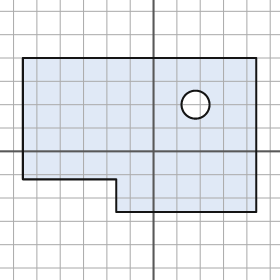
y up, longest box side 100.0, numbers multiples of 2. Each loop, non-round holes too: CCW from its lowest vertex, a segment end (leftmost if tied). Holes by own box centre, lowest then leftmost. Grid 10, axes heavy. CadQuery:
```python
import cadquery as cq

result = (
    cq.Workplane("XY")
    .moveTo(-16.0, -26.0)
    .lineTo(44.0, -26.0)
    .lineTo(44.0, 40.0)
    .lineTo(-56.0, 40.0)
    .lineTo(-56.0, -12.0)
    .lineTo(-16.0, -12.0)
    .close()
    .moveTo(18.0, 20.0)
    .circle(6.0)
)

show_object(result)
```